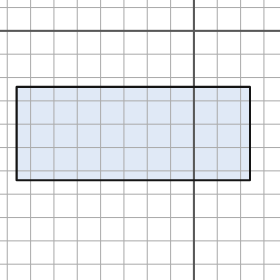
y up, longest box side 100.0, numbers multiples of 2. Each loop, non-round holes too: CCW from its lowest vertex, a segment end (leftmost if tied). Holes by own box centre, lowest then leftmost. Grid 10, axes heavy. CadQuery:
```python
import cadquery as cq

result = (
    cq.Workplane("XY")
    .moveTo(-76.0, -64.0)
    .lineTo(24.0, -64.0)
    .lineTo(24.0, -24.0)
    .lineTo(-76.0, -24.0)
    .close()
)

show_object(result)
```